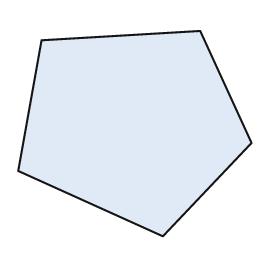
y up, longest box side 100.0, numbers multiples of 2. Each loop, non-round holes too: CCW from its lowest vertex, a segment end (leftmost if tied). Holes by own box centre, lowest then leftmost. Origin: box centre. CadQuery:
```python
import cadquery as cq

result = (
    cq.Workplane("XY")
    .moveTo(12.0, -44.0)
    .lineTo(50.0, -4.0)
    .lineTo(28.0, 44.0)
    .lineTo(-40.0, 40.0)
    .lineTo(-50.0, -16.0)
    .close()
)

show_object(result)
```